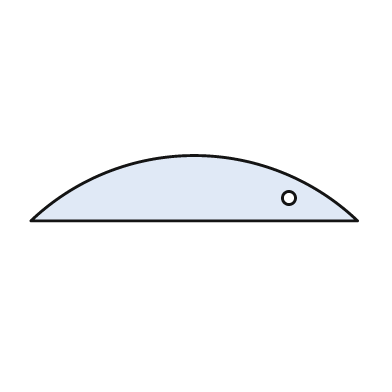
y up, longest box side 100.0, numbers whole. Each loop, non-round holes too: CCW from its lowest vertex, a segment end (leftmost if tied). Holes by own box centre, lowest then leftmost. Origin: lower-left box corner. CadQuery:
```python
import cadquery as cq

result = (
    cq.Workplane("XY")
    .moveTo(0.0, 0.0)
    .lineTo(100.0, 0.0)
    .threePointArc((50.0, 20.0), (0.0, 0.0))
    .close()
    .moveTo(79.0, 7.0)
    .circle(2.0)
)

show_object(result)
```